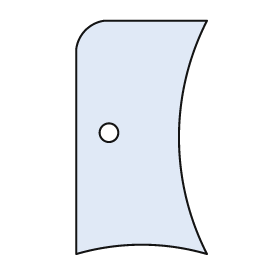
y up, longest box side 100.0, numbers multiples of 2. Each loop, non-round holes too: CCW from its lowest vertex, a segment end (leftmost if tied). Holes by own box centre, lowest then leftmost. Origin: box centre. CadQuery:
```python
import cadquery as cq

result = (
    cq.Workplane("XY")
    .moveTo(-28.0, -50.0)
    .threePointArc((0.0, -46.0), (28.0, -50.0))
    .threePointArc((16.0, 0.0), (28.0, 50.0))
    .lineTo(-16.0, 50.0)
    .threePointArc((-24.0, 46.0), (-28.0, 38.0))
    .close()
    .moveTo(-14.0, 2.0)
    .circle(4.0)
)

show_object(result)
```